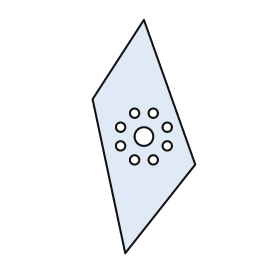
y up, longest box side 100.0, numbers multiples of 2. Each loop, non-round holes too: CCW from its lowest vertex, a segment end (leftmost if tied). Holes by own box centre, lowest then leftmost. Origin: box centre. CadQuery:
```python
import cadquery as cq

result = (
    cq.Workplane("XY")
    .moveTo(-8.0, -50.0)
    .lineTo(22.0, -12.0)
    .lineTo(0.0, 50.0)
    .lineTo(-22.0, 16.0)
    .close()
    .moveTo(-4.0, -10.0)
    .circle(2.0)
    .moveTo(4.0, -10.0)
    .circle(2.0)
    .moveTo(-10.0, -4.0)
    .circle(2.0)
    .moveTo(10.0, -4.0)
    .circle(2.0)
    .moveTo(0.0, 0.0)
    .circle(4.0)
    .moveTo(-10.0, 4.0)
    .circle(2.0)
    .moveTo(10.0, 4.0)
    .circle(2.0)
    .moveTo(-4.0, 10.0)
    .circle(2.0)
    .moveTo(4.0, 10.0)
    .circle(2.0)
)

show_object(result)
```